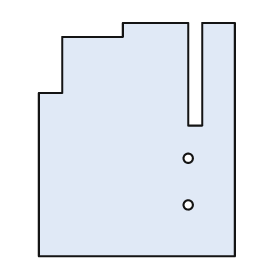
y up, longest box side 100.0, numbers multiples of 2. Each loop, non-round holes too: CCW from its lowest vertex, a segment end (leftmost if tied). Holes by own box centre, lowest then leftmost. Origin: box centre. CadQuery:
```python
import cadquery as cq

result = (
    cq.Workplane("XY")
    .moveTo(-42.0, -50.0)
    .lineTo(42.0, -50.0)
    .lineTo(42.0, 50.0)
    .lineTo(28.0, 50.0)
    .lineTo(28.0, 6.0)
    .lineTo(22.0, 6.0)
    .lineTo(22.0, 50.0)
    .lineTo(-6.0, 50.0)
    .lineTo(-6.0, 44.0)
    .lineTo(-32.0, 44.0)
    .lineTo(-32.0, 20.0)
    .lineTo(-42.0, 20.0)
    .close()
    .moveTo(22.0, -28.0)
    .circle(2.0)
    .moveTo(22.0, -8.0)
    .circle(2.0)
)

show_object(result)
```